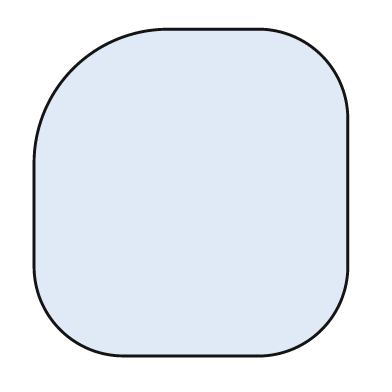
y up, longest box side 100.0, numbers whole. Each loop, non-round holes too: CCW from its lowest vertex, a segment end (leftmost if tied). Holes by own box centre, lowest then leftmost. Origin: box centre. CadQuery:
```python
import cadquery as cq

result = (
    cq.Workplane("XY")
    .moveTo(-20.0, -50.0)
    .lineTo(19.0, -50.0)
    .threePointArc((40.0, -42.0), (48.0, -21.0))
    .lineTo(48.0, 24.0)
    .threePointArc((40.0, 42.0), (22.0, 50.0))
    .lineTo(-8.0, 50.0)
    .threePointArc((-36.0, 38.0), (-48.0, 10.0))
    .lineTo(-48.0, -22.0)
    .threePointArc((-40.0, -42.0), (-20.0, -50.0))
    .close()
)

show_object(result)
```